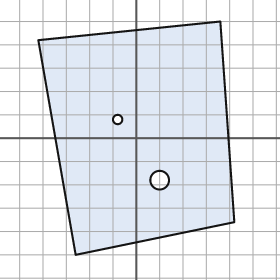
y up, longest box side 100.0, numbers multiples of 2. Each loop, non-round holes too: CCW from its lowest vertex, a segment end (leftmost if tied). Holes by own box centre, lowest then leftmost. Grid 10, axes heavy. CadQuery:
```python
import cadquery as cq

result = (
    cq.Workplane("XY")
    .moveTo(-26.0, -50.0)
    .lineTo(42.0, -36.0)
    .lineTo(36.0, 50.0)
    .lineTo(-42.0, 42.0)
    .close()
    .moveTo(10.0, -18.0)
    .circle(4.0)
    .moveTo(-8.0, 8.0)
    .circle(2.0)
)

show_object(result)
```